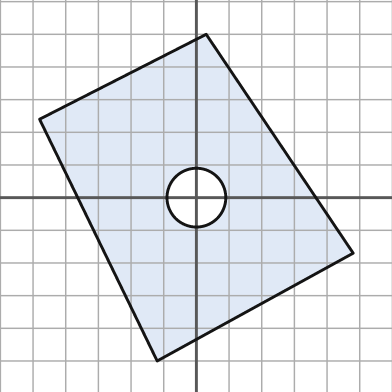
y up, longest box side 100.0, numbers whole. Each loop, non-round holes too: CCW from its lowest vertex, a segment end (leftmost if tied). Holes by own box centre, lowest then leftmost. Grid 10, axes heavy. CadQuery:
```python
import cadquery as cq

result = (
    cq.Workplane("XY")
    .moveTo(-12.0, -50.0)
    .lineTo(48.0, -17.0)
    .lineTo(3.0, 50.0)
    .lineTo(-48.0, 24.0)
    .close()
    .moveTo(0.0, 0.0)
    .circle(9.0)
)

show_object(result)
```